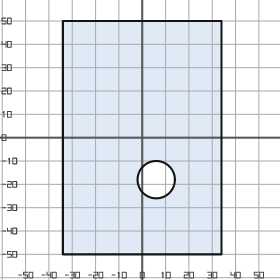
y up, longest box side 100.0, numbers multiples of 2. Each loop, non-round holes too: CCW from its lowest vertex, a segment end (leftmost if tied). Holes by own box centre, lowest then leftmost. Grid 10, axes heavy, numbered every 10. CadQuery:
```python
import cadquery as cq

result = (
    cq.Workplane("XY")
    .moveTo(-34.0, -50.0)
    .lineTo(34.0, -50.0)
    .lineTo(34.0, 50.0)
    .lineTo(-34.0, 50.0)
    .close()
    .moveTo(6.0, -18.0)
    .circle(8.0)
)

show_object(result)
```